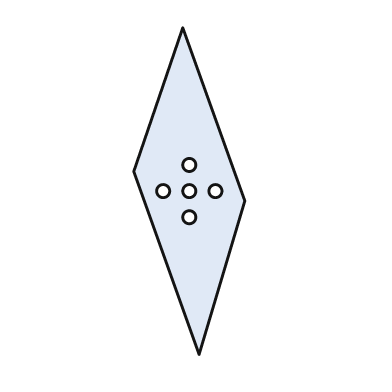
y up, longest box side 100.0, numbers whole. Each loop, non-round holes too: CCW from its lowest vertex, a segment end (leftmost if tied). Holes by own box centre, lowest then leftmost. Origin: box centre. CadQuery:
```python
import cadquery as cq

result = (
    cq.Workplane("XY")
    .moveTo(3.0, -50.0)
    .lineTo(17.0, -3.0)
    .lineTo(-2.0, 50.0)
    .lineTo(-17.0, 6.0)
    .close()
    .moveTo(0.0, -8.0)
    .circle(2.0)
    .moveTo(-8.0, 0.0)
    .circle(2.0)
    .moveTo(0.0, 0.0)
    .circle(2.0)
    .moveTo(8.0, 0.0)
    .circle(2.0)
    .moveTo(0.0, 8.0)
    .circle(2.0)
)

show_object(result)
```